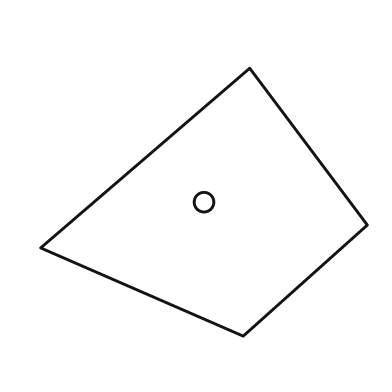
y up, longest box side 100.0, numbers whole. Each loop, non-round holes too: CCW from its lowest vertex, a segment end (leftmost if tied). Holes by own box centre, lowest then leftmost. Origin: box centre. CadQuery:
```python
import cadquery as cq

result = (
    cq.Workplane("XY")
    .moveTo(12.0, -41.0)
    .lineTo(50.0, -7.0)
    .lineTo(14.0, 41.0)
    .lineTo(-50.0, -14.0)
    .close()
    .moveTo(0.0, 0.0)
    .circle(3.0)
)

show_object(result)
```